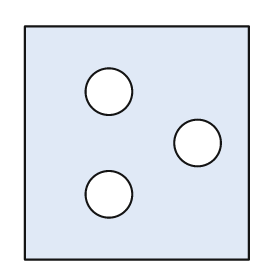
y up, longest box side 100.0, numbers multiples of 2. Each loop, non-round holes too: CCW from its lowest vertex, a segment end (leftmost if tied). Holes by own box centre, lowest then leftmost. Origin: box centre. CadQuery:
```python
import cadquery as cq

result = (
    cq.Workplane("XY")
    .moveTo(-48.0, -50.0)
    .lineTo(48.0, -50.0)
    .lineTo(48.0, 50.0)
    .lineTo(-48.0, 50.0)
    .close()
    .moveTo(-12.0, -22.0)
    .circle(10.0)
    .moveTo(26.0, 0.0)
    .circle(10.0)
    .moveTo(-12.0, 22.0)
    .circle(10.0)
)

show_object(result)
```